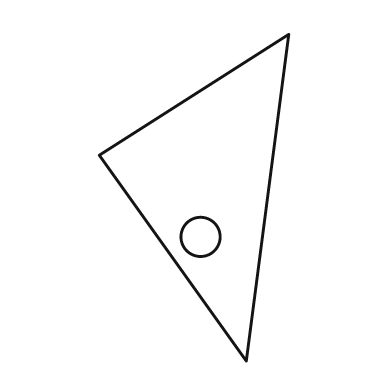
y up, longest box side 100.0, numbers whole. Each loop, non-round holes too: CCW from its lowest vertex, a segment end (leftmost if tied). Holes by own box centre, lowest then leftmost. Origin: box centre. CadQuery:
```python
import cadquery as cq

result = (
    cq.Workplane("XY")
    .moveTo(16.0, -50.0)
    .lineTo(29.0, 50.0)
    .lineTo(-29.0, 13.0)
    .close()
    .moveTo(2.0, -12.0)
    .circle(6.0)
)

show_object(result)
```